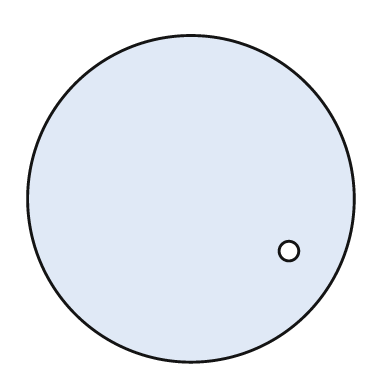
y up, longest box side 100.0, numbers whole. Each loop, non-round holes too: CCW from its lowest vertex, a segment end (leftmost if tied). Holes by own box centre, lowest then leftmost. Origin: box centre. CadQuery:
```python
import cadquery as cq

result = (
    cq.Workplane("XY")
    .moveTo(0.0, 0.0)
    .circle(50.0)
    .moveTo(30.0, -16.0)
    .circle(3.0)
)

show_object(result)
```